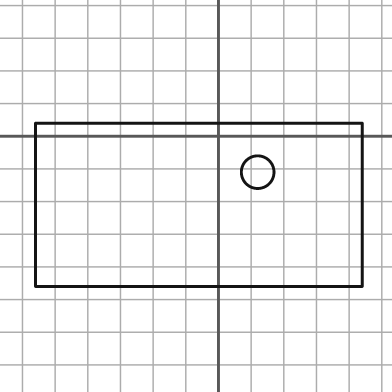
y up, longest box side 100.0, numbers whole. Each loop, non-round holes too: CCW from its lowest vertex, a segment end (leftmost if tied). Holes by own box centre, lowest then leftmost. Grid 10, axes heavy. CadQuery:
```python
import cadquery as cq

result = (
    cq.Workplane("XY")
    .moveTo(-56.0, -46.0)
    .lineTo(44.0, -46.0)
    .lineTo(44.0, 4.0)
    .lineTo(-56.0, 4.0)
    .close()
    .moveTo(12.0, -11.0)
    .circle(5.0)
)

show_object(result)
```